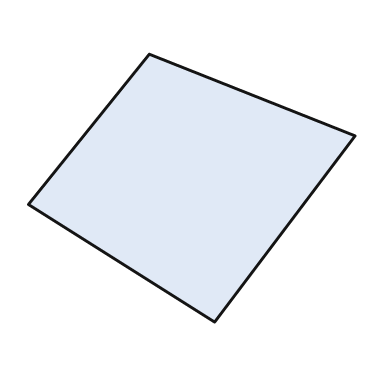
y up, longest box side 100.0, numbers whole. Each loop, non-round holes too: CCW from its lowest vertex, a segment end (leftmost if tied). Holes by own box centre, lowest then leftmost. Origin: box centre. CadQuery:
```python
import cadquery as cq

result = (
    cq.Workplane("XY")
    .moveTo(7.0, -41.0)
    .lineTo(50.0, 16.0)
    .lineTo(-13.0, 41.0)
    .lineTo(-50.0, -5.0)
    .close()
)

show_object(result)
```